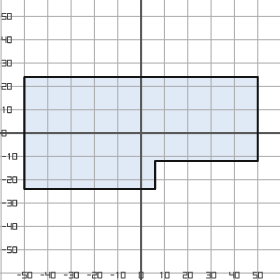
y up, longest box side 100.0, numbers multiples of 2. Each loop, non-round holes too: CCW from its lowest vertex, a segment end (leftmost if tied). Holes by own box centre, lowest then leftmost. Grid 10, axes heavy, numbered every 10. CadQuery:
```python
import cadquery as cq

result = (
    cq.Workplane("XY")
    .moveTo(-50.0, -24.0)
    .lineTo(6.0, -24.0)
    .lineTo(6.0, -12.0)
    .lineTo(50.0, -12.0)
    .lineTo(50.0, 24.0)
    .lineTo(-50.0, 24.0)
    .close()
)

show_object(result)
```